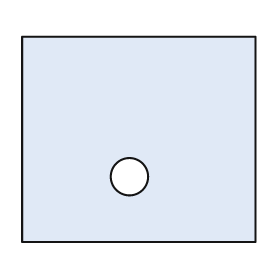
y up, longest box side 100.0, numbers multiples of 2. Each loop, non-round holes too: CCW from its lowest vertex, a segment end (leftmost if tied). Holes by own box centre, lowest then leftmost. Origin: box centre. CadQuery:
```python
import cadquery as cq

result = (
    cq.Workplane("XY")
    .moveTo(-50.0, -44.0)
    .lineTo(50.0, -44.0)
    .lineTo(50.0, 44.0)
    .lineTo(-50.0, 44.0)
    .close()
    .moveTo(-4.0, -16.0)
    .circle(8.0)
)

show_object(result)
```